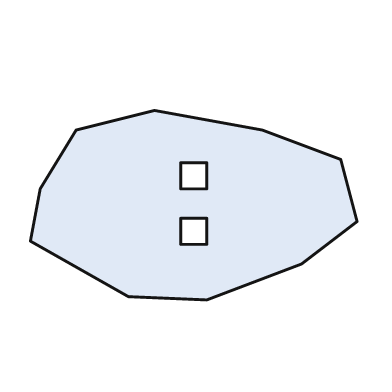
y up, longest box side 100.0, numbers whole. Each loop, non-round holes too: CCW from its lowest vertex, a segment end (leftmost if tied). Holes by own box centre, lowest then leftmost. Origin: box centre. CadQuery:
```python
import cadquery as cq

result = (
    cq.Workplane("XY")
    .moveTo(4.0, -29.0)
    .lineTo(33.0, -18.0)
    .lineTo(50.0, -5.0)
    .lineTo(45.0, 14.0)
    .lineTo(21.0, 23.0)
    .lineTo(-12.0, 29.0)
    .lineTo(-36.0, 23.0)
    .lineTo(-47.0, 5.0)
    .lineTo(-50.0, -11.0)
    .lineTo(-20.0, -28.0)
    .close()
    .moveTo(-4.0, -12.0)
    .lineTo(4.0, -12.0)
    .lineTo(4.0, -4.0)
    .lineTo(-4.0, -4.0)
    .close()
    .moveTo(-4.0, 5.0)
    .lineTo(4.0, 5.0)
    .lineTo(4.0, 13.0)
    .lineTo(-4.0, 13.0)
    .close()
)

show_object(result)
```